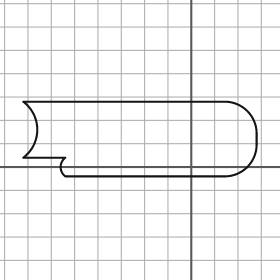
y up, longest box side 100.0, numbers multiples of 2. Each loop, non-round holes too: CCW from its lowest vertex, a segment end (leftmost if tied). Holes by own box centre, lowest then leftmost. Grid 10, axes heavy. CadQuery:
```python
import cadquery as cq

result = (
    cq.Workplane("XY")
    .moveTo(-54.0, -4.0)
    .lineTo(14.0, -4.0)
    .threePointArc((24.0, 0.0), (28.0, 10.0))
    .lineTo(28.0, 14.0)
    .threePointArc((24.0, 24.0), (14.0, 28.0))
    .lineTo(-72.0, 28.0)
    .threePointArc((-66.0, 16.0), (-72.0, 4.0))
    .lineTo(-54.0, 4.0)
    .threePointArc((-56.0, 0.0), (-54.0, -4.0))
    .close()
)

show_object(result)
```